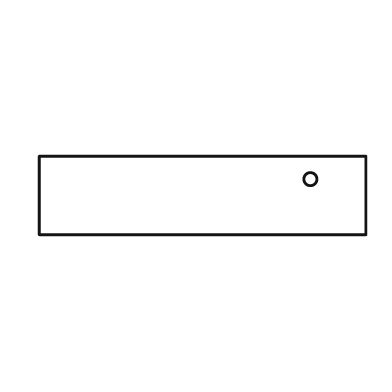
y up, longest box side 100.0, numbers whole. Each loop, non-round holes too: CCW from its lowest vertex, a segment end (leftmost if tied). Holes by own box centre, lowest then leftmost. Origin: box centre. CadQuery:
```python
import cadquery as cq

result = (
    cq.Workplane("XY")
    .moveTo(-50.0, -12.0)
    .lineTo(50.0, -12.0)
    .lineTo(50.0, 12.0)
    .lineTo(-50.0, 12.0)
    .close()
    .moveTo(33.0, 5.0)
    .circle(2.0)
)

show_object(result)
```